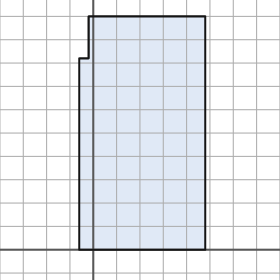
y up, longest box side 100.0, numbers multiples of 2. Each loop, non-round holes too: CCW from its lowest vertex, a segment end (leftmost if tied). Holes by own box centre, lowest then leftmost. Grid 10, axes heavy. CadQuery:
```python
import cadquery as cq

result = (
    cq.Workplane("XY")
    .moveTo(-6.0, 0.0)
    .lineTo(48.0, 0.0)
    .lineTo(48.0, 100.0)
    .lineTo(-2.0, 100.0)
    .lineTo(-2.0, 82.0)
    .lineTo(-6.0, 82.0)
    .close()
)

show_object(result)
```